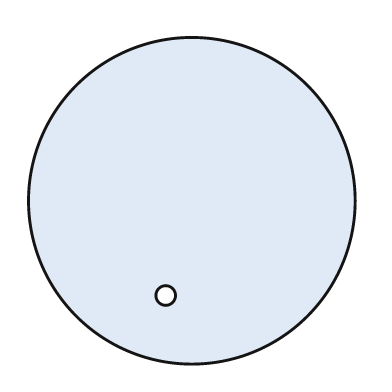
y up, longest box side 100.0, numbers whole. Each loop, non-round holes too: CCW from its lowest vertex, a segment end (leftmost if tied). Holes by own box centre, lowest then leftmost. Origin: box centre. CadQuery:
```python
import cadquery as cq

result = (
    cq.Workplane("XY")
    .moveTo(0.0, 0.0)
    .circle(50.0)
    .moveTo(-8.0, -29.0)
    .circle(3.0)
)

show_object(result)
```